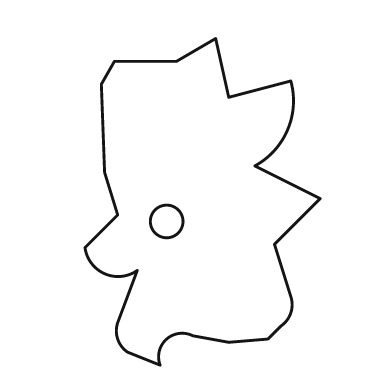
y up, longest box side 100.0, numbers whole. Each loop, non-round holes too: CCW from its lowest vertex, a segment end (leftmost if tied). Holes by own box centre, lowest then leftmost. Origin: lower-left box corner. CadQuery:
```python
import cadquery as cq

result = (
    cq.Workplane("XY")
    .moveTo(23.0, 0.0)
    .threePointArc((25.0, 8.0), (33.0, 9.0))
    .lineTo(44.0, 7.0)
    .lineTo(56.0, 8.0)
    .lineTo(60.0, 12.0)
    .threePointArc((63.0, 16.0), (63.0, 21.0))
    .lineTo(58.0, 37.0)
    .lineTo(72.0, 51.0)
    .lineTo(52.0, 61.0)
    .threePointArc((62.0, 72.0), (63.0, 87.0))
    .lineTo(44.0, 82.0)
    .lineTo(40.0, 100.0)
    .lineTo(28.0, 93.0)
    .lineTo(9.0, 93.0)
    .lineTo(5.0, 86.0)
    .lineTo(6.0, 59.0)
    .lineTo(10.0, 46.0)
    .lineTo(0.0, 36.0)
    .threePointArc((6.0, 28.0), (16.0, 29.0))
    .lineTo(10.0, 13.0)
    .threePointArc((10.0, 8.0), (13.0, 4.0))
    .close()
    .moveTo(25.0, 44.0)
    .circle(5.0)
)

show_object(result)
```